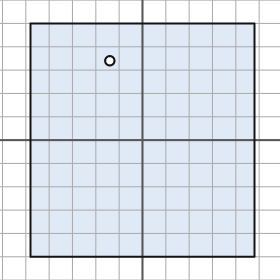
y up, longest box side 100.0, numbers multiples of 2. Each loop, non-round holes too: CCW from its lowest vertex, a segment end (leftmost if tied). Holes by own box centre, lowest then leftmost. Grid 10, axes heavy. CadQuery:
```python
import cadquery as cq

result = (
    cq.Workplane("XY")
    .moveTo(-48.0, -50.0)
    .lineTo(48.0, -50.0)
    .lineTo(48.0, 50.0)
    .lineTo(-48.0, 50.0)
    .close()
    .moveTo(-14.0, 34.0)
    .circle(2.0)
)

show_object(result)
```